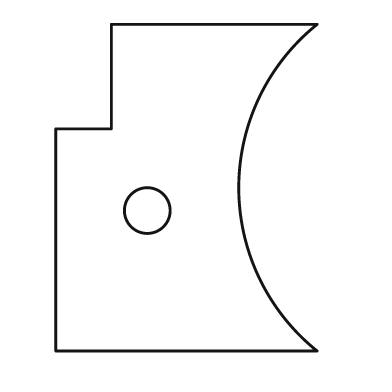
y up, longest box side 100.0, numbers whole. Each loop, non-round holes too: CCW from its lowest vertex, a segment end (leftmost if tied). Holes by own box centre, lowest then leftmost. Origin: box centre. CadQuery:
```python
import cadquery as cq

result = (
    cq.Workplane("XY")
    .moveTo(-40.0, -50.0)
    .lineTo(40.0, -50.0)
    .threePointArc((16.0, 0.0), (40.0, 50.0))
    .lineTo(-23.0, 50.0)
    .lineTo(-23.0, 18.0)
    .lineTo(-40.0, 18.0)
    .close()
    .moveTo(-12.0, -7.0)
    .circle(7.0)
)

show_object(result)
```